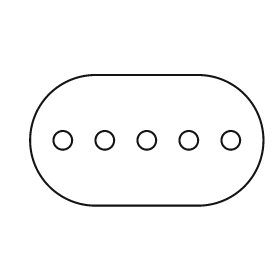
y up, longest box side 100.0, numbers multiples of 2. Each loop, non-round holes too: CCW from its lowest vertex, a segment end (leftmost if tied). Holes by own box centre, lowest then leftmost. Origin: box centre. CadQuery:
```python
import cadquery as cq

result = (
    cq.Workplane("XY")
    .moveTo(-22.0, -28.0)
    .lineTo(22.0, -28.0)
    .threePointArc((50.0, 0.0), (22.0, 28.0))
    .lineTo(-22.0, 28.0)
    .threePointArc((-50.0, 0.0), (-22.0, -28.0))
    .close()
    .moveTo(-36.0, 0.0)
    .circle(4.0)
    .moveTo(-18.0, 0.0)
    .circle(4.0)
    .moveTo(0.0, 0.0)
    .circle(4.0)
    .moveTo(18.0, 0.0)
    .circle(4.0)
    .moveTo(36.0, 0.0)
    .circle(4.0)
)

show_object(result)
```